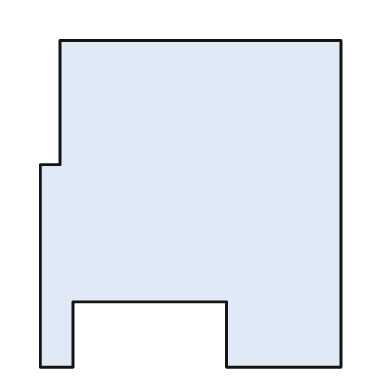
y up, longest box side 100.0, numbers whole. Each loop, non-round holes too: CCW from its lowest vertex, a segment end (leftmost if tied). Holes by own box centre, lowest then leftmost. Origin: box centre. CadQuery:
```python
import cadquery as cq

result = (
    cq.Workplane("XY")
    .moveTo(-46.0, -50.0)
    .lineTo(-36.0, -50.0)
    .lineTo(-36.0, -30.0)
    .lineTo(11.0, -30.0)
    .lineTo(11.0, -50.0)
    .lineTo(46.0, -50.0)
    .lineTo(46.0, 50.0)
    .lineTo(-40.0, 50.0)
    .lineTo(-40.0, 12.0)
    .lineTo(-46.0, 12.0)
    .close()
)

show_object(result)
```